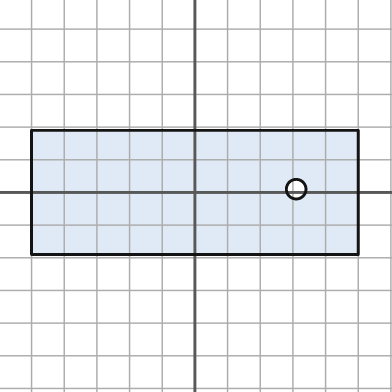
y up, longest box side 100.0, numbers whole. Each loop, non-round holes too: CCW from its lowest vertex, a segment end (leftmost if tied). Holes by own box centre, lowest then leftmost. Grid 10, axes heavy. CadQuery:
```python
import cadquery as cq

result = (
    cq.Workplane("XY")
    .moveTo(-50.0, -19.0)
    .lineTo(50.0, -19.0)
    .lineTo(50.0, 19.0)
    .lineTo(-50.0, 19.0)
    .close()
    .moveTo(31.0, 1.0)
    .circle(3.0)
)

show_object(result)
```